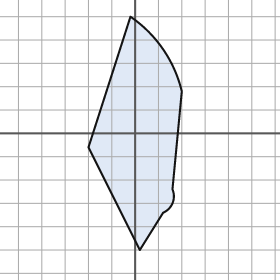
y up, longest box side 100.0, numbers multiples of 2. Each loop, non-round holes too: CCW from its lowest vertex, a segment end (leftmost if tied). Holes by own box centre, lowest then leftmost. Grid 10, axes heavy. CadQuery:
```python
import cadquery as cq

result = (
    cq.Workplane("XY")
    .moveTo(2.0, -50.0)
    .lineTo(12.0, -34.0)
    .threePointArc((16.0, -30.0), (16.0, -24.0))
    .lineTo(20.0, 18.0)
    .threePointArc((12.0, 36.0), (-2.0, 50.0))
    .lineTo(-20.0, -6.0)
    .close()
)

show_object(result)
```